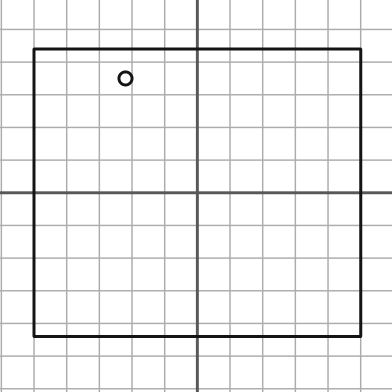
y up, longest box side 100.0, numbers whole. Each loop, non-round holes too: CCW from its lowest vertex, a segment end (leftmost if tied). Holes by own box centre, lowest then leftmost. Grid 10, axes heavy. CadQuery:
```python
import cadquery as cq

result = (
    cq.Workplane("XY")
    .moveTo(-50.0, -44.0)
    .lineTo(50.0, -44.0)
    .lineTo(50.0, 44.0)
    .lineTo(-50.0, 44.0)
    .close()
    .moveTo(-22.0, 35.0)
    .circle(2.0)
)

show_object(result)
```